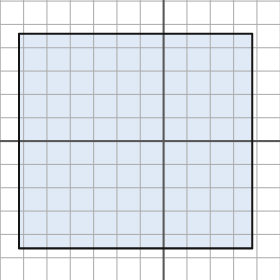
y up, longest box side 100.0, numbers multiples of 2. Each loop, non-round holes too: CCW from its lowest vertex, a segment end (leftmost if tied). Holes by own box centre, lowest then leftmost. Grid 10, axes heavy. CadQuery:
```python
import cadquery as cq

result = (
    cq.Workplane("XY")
    .moveTo(-62.0, -46.0)
    .lineTo(38.0, -46.0)
    .lineTo(38.0, 46.0)
    .lineTo(-62.0, 46.0)
    .close()
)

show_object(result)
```